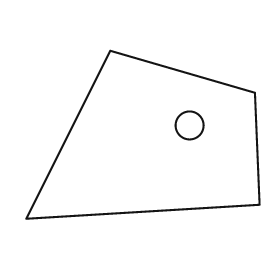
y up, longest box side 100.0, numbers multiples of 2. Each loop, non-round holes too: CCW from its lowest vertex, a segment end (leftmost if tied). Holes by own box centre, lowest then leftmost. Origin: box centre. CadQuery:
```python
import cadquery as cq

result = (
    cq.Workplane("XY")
    .moveTo(-50.0, -36.0)
    .lineTo(50.0, -30.0)
    .lineTo(48.0, 18.0)
    .lineTo(-14.0, 36.0)
    .close()
    .moveTo(20.0, 4.0)
    .circle(6.0)
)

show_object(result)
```